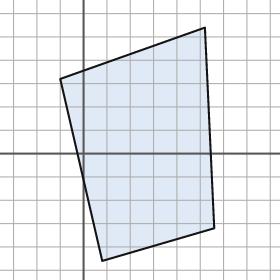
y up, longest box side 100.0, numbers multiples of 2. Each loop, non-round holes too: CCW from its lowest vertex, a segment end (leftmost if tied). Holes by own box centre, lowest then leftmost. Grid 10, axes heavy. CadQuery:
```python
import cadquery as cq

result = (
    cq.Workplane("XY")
    .moveTo(8.0, -46.0)
    .lineTo(56.0, -32.0)
    .lineTo(52.0, 54.0)
    .lineTo(-10.0, 32.0)
    .close()
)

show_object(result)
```